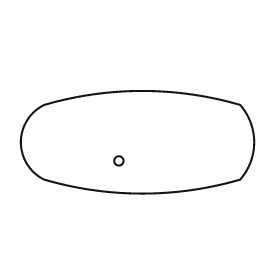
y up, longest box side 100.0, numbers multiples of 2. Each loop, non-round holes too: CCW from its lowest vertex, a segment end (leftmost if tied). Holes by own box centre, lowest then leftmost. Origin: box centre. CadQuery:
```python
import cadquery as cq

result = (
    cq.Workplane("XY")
    .moveTo(-40.0, -16.0)
    .threePointArc((2.0, -22.0), (44.0, -16.0))
    .threePointArc((50.0, 0.0), (44.0, 16.0))
    .threePointArc((2.0, 22.0), (-40.0, 16.0))
    .threePointArc((-50.0, 0.0), (-40.0, -16.0))
    .close()
    .moveTo(-8.0, -8.0)
    .circle(2.0)
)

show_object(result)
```